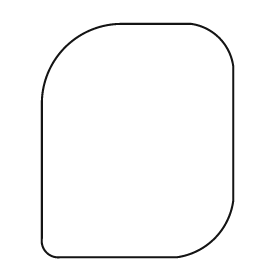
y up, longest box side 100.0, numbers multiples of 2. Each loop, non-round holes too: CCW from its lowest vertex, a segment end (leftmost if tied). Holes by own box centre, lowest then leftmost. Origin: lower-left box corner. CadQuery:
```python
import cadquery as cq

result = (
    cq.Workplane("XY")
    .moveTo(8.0, 0.0)
    .lineTo(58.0, 0.0)
    .threePointArc((74.0, 8.0), (82.0, 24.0))
    .lineTo(82.0, 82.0)
    .threePointArc((76.0, 94.0), (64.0, 100.0))
    .lineTo(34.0, 100.0)
    .threePointArc((10.0, 90.0), (0.0, 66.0))
    .lineTo(0.0, 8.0)
    .threePointArc((2.0, 2.0), (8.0, 0.0))
    .close()
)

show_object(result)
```